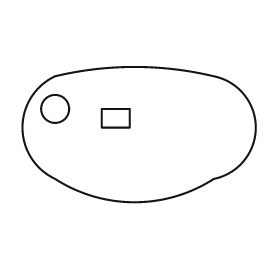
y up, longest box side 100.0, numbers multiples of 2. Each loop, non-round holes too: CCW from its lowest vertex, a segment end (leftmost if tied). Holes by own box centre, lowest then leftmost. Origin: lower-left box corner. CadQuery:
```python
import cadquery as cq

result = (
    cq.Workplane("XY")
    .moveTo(14.0, 10.0)
    .threePointArc((48.0, 0.0), (82.0, 10.0))
    .threePointArc((100.0, 32.0), (82.0, 54.0))
    .threePointArc((48.0, 58.0), (14.0, 54.0))
    .threePointArc((0.0, 32.0), (14.0, 10.0))
    .close()
    .moveTo(34.0, 32.0)
    .lineTo(46.0, 32.0)
    .lineTo(46.0, 40.0)
    .lineTo(34.0, 40.0)
    .close()
    .moveTo(14.0, 40.0)
    .circle(6.0)
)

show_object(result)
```